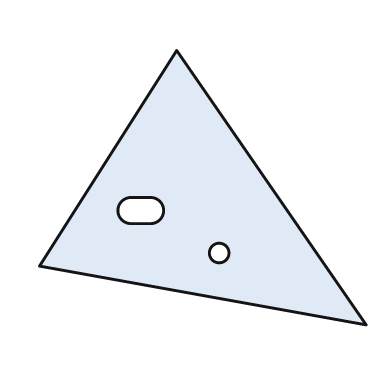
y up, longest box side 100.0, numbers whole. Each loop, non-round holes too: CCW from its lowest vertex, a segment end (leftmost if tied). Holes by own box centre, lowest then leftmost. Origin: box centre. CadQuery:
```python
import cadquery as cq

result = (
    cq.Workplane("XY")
    .moveTo(50.0, -42.0)
    .lineTo(-8.0, 42.0)
    .lineTo(-50.0, -24.0)
    .close()
    .moveTo(5.0, -20.0)
    .circle(3.0)
    .moveTo(-22.0, -11.0)
    .lineTo(-16.0, -11.0)
    .threePointArc((-12.0, -7.0), (-16.0, -3.0))
    .lineTo(-22.0, -3.0)
    .threePointArc((-26.0, -7.0), (-22.0, -11.0))
    .close()
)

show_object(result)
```